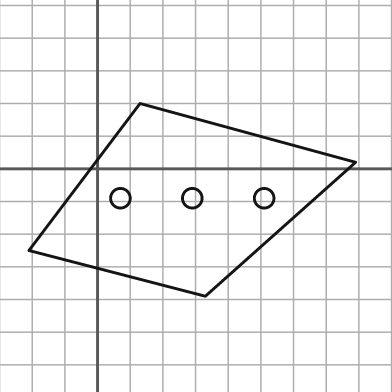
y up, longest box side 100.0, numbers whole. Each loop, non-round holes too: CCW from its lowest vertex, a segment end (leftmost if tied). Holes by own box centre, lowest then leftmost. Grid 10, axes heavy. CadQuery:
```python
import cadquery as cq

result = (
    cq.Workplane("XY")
    .moveTo(33.0, -39.0)
    .lineTo(79.0, 2.0)
    .lineTo(13.0, 20.0)
    .lineTo(-21.0, -25.0)
    .close()
    .moveTo(7.0, -9.0)
    .circle(3.0)
    .moveTo(29.0, -9.0)
    .circle(3.0)
    .moveTo(51.0, -9.0)
    .circle(3.0)
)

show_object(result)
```